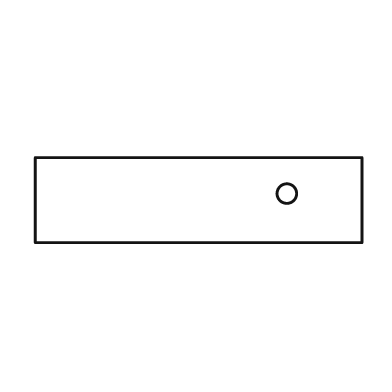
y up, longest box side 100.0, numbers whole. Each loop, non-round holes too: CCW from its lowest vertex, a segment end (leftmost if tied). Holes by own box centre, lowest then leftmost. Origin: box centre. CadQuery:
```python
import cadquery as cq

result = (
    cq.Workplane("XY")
    .moveTo(-50.0, -13.0)
    .lineTo(50.0, -13.0)
    .lineTo(50.0, 13.0)
    .lineTo(-50.0, 13.0)
    .close()
    .moveTo(27.0, 2.0)
    .circle(3.0)
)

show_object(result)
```